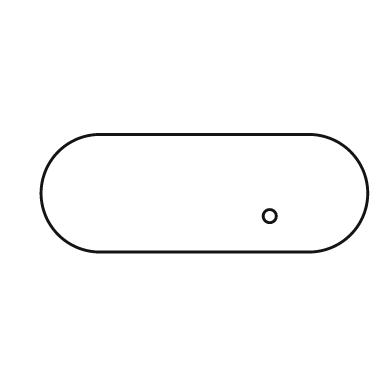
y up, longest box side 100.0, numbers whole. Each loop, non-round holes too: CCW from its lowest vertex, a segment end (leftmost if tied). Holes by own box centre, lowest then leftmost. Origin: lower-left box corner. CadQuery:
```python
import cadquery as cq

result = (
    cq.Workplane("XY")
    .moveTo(18.0, 0.0)
    .lineTo(82.0, 0.0)
    .threePointArc((100.0, 18.0), (82.0, 36.0))
    .lineTo(18.0, 36.0)
    .threePointArc((0.0, 18.0), (18.0, 0.0))
    .close()
    .moveTo(70.0, 11.0)
    .circle(2.0)
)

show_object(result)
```